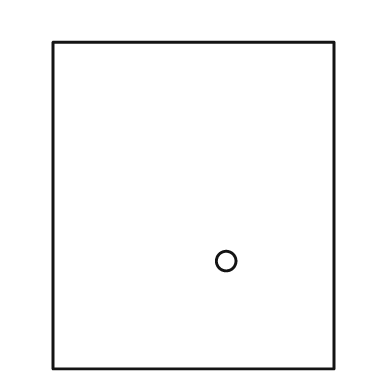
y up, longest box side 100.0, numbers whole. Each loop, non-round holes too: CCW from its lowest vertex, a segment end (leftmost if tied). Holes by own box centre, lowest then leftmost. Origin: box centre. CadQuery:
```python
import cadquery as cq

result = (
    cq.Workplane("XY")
    .moveTo(-43.0, -50.0)
    .lineTo(43.0, -50.0)
    .lineTo(43.0, 50.0)
    .lineTo(-43.0, 50.0)
    .close()
    .moveTo(10.0, -17.0)
    .circle(3.0)
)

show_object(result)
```